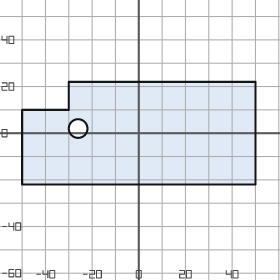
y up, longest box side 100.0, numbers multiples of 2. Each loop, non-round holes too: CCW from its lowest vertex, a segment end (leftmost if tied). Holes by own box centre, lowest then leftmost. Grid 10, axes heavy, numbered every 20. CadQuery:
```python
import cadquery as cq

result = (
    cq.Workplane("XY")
    .moveTo(-50.0, -22.0)
    .lineTo(50.0, -22.0)
    .lineTo(50.0, 22.0)
    .lineTo(-30.0, 22.0)
    .lineTo(-30.0, 10.0)
    .lineTo(-50.0, 10.0)
    .close()
    .moveTo(-26.0, 2.0)
    .circle(4.0)
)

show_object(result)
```